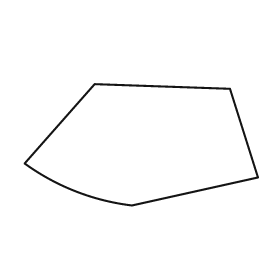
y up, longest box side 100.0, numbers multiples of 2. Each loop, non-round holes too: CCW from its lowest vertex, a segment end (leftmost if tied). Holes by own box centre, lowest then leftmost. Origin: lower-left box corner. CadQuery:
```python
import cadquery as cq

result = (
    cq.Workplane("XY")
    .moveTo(46.0, 0.0)
    .lineTo(100.0, 12.0)
    .lineTo(88.0, 50.0)
    .lineTo(30.0, 52.0)
    .lineTo(0.0, 18.0)
    .threePointArc((22.0, 6.0), (46.0, 0.0))
    .close()
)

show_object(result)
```